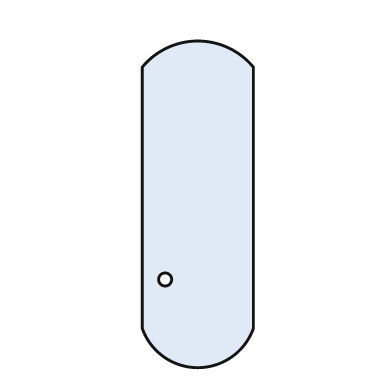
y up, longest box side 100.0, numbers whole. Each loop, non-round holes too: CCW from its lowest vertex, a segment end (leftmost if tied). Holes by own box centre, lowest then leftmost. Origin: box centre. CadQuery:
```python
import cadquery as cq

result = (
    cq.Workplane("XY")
    .moveTo(-17.0, -38.0)
    .threePointArc((0.0, -50.0), (17.0, -38.0))
    .lineTo(17.0, 42.0)
    .threePointArc((0.0, 50.0), (-17.0, 42.0))
    .close()
    .moveTo(-10.0, -23.0)
    .circle(2.0)
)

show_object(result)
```